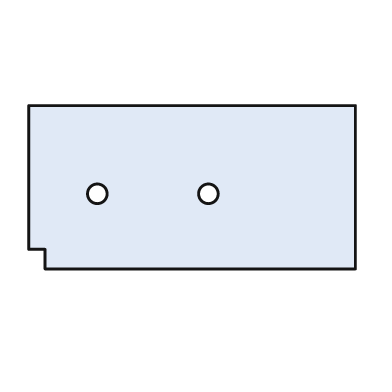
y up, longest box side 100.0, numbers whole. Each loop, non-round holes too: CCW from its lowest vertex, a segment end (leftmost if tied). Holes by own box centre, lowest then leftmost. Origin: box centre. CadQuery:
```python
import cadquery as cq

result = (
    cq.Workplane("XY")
    .moveTo(-45.0, -25.0)
    .lineTo(50.0, -25.0)
    .lineTo(50.0, 25.0)
    .lineTo(-50.0, 25.0)
    .lineTo(-50.0, -19.0)
    .lineTo(-45.0, -19.0)
    .close()
    .moveTo(-29.0, -2.0)
    .circle(3.0)
    .moveTo(5.0, -2.0)
    .circle(3.0)
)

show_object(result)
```